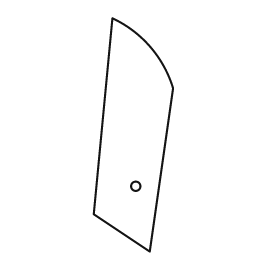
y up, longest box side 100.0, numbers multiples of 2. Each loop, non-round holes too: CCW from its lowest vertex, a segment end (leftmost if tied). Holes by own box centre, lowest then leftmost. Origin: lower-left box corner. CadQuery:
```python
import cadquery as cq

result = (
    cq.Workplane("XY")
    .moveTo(24.0, 0.0)
    .lineTo(34.0, 70.0)
    .threePointArc((24.0, 88.0), (8.0, 100.0))
    .lineTo(0.0, 16.0)
    .close()
    .moveTo(18.0, 28.0)
    .circle(2.0)
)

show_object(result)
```